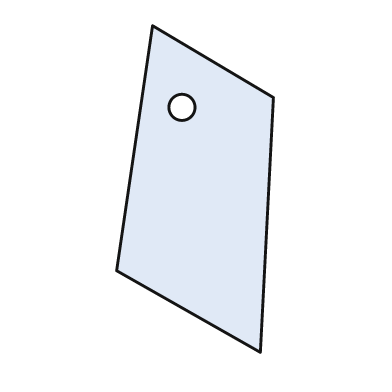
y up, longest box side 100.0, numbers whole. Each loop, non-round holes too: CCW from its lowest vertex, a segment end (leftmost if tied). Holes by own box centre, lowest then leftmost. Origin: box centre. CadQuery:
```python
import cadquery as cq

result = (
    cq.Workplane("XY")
    .moveTo(20.0, -50.0)
    .lineTo(24.0, 28.0)
    .lineTo(-13.0, 50.0)
    .lineTo(-24.0, -25.0)
    .close()
    .moveTo(-4.0, 25.0)
    .circle(4.0)
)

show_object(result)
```